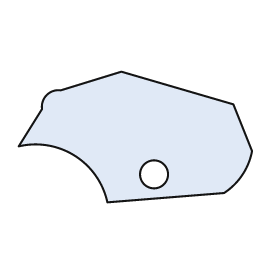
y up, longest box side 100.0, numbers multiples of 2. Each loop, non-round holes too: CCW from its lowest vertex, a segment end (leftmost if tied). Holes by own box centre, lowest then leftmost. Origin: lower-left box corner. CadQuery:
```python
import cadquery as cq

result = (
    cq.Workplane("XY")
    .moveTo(38.0, 0.0)
    .lineTo(88.0, 4.0)
    .threePointArc((96.0, 12.0), (100.0, 22.0))
    .lineTo(92.0, 42.0)
    .lineTo(44.0, 56.0)
    .lineTo(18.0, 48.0)
    .threePointArc((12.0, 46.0), (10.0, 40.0))
    .lineTo(0.0, 24.0)
    .threePointArc((24.0, 20.0), (38.0, 0.0))
    .close()
    .moveTo(58.0, 12.0)
    .circle(6.0)
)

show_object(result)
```